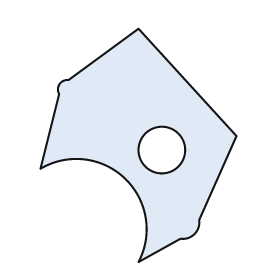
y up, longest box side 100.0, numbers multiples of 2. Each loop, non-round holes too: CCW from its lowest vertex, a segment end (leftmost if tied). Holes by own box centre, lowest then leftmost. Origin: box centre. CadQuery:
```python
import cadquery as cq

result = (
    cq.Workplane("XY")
    .moveTo(0.0, -50.0)
    .lineTo(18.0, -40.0)
    .threePointArc((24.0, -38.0), (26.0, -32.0))
    .lineTo(42.0, 4.0)
    .lineTo(0.0, 50.0)
    .lineTo(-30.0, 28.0)
    .threePointArc((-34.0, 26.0), (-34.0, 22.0))
    .lineTo(-42.0, -10.0)
    .threePointArc((-6.0, -14.0), (0.0, -50.0))
    .close()
    .moveTo(10.0, -2.0)
    .circle(10.0)
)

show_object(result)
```